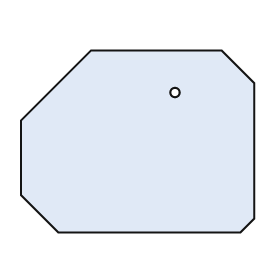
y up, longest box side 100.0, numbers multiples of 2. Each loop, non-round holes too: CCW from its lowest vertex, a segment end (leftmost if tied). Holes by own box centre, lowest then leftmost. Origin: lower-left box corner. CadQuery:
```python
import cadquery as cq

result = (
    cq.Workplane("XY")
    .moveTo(16.0, 0.0)
    .lineTo(94.0, 0.0)
    .lineTo(100.0, 6.0)
    .lineTo(100.0, 64.0)
    .lineTo(86.0, 78.0)
    .lineTo(30.0, 78.0)
    .lineTo(0.0, 48.0)
    .lineTo(0.0, 16.0)
    .close()
    .moveTo(66.0, 60.0)
    .circle(2.0)
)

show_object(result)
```